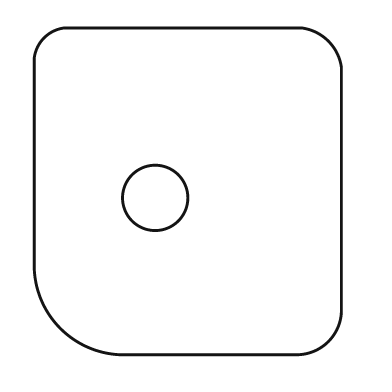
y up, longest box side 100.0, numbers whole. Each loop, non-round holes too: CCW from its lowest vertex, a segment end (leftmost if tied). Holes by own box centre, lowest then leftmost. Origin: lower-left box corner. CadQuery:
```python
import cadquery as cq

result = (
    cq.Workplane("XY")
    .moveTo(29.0, 0.0)
    .lineTo(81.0, 0.0)
    .threePointArc((90.0, 4.0), (94.0, 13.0))
    .lineTo(94.0, 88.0)
    .threePointArc((90.0, 96.0), (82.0, 100.0))
    .lineTo(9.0, 100.0)
    .threePointArc((3.0, 97.0), (0.0, 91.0))
    .lineTo(0.0, 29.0)
    .threePointArc((8.0, 8.0), (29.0, 0.0))
    .close()
    .moveTo(37.0, 48.0)
    .circle(10.0)
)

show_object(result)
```